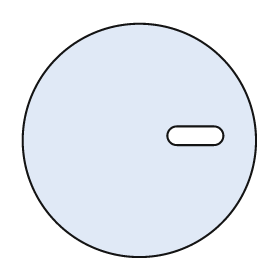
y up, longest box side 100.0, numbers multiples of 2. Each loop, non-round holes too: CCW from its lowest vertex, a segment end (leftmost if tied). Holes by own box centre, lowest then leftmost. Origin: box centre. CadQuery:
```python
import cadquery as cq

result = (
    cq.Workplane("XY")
    .moveTo(0.0, 0.0)
    .circle(50.0)
    .moveTo(16.0, -2.0)
    .lineTo(32.0, -2.0)
    .threePointArc((36.0, 2.0), (32.0, 6.0))
    .lineTo(16.0, 6.0)
    .threePointArc((12.0, 2.0), (16.0, -2.0))
    .close()
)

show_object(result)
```